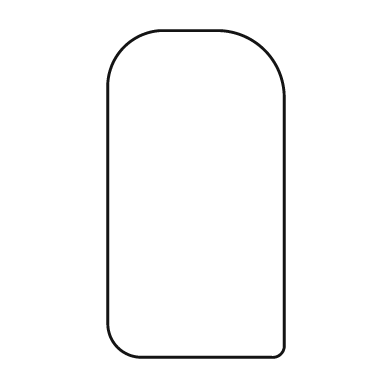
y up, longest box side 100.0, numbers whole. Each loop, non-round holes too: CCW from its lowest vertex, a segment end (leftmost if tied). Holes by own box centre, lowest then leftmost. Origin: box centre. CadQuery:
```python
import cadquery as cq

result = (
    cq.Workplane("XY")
    .moveTo(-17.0, -50.0)
    .lineTo(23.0, -50.0)
    .threePointArc((26.0, -49.0), (27.0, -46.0))
    .lineTo(27.0, 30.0)
    .threePointArc((21.0, 44.0), (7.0, 50.0))
    .lineTo(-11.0, 50.0)
    .threePointArc((-22.0, 45.0), (-27.0, 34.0))
    .lineTo(-27.0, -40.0)
    .threePointArc((-24.0, -47.0), (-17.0, -50.0))
    .close()
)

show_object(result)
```